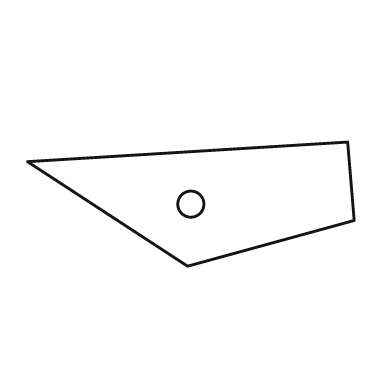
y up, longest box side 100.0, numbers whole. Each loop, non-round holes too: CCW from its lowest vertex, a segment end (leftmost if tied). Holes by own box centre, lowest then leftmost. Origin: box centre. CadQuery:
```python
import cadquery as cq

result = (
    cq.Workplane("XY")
    .moveTo(-1.0, -19.0)
    .lineTo(50.0, -5.0)
    .lineTo(48.0, 19.0)
    .lineTo(-50.0, 13.0)
    .close()
    .moveTo(0.0, 0.0)
    .circle(4.0)
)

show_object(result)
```